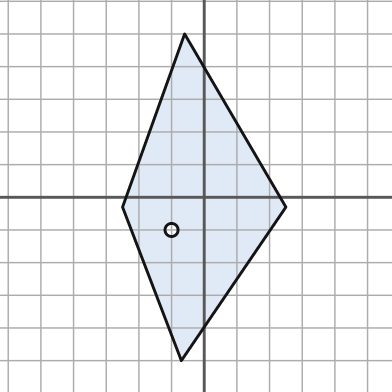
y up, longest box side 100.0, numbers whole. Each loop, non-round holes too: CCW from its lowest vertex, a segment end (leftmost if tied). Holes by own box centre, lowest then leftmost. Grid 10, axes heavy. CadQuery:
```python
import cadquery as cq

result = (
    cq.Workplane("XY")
    .moveTo(-7.0, -50.0)
    .lineTo(25.0, -3.0)
    .lineTo(-6.0, 50.0)
    .lineTo(-25.0, -3.0)
    .close()
    .moveTo(-10.0, -10.0)
    .circle(2.0)
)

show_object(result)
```